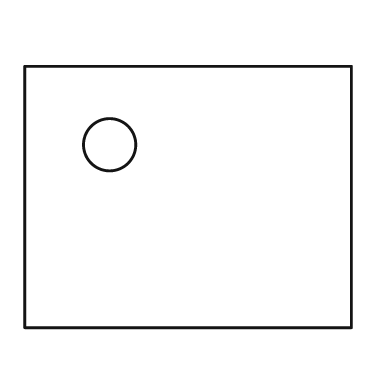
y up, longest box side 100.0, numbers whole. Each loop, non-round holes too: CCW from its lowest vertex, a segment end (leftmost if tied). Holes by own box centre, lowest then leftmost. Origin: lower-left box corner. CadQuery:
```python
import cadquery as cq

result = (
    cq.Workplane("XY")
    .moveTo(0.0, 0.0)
    .lineTo(100.0, 0.0)
    .lineTo(100.0, 80.0)
    .lineTo(0.0, 80.0)
    .close()
    .moveTo(26.0, 56.0)
    .circle(8.0)
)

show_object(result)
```